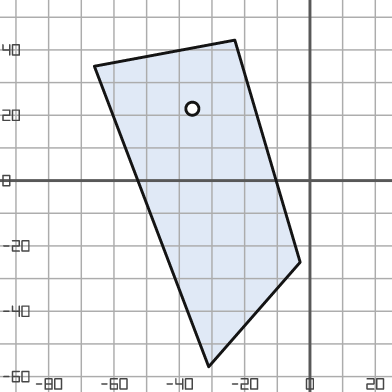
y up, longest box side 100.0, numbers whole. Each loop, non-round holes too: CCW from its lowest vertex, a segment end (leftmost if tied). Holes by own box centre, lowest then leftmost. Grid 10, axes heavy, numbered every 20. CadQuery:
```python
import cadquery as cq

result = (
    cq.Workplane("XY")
    .moveTo(-31.0, -57.0)
    .lineTo(-3.0, -25.0)
    .lineTo(-23.0, 43.0)
    .lineTo(-66.0, 35.0)
    .close()
    .moveTo(-36.0, 22.0)
    .circle(2.0)
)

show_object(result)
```